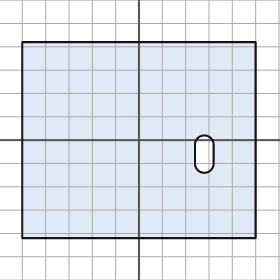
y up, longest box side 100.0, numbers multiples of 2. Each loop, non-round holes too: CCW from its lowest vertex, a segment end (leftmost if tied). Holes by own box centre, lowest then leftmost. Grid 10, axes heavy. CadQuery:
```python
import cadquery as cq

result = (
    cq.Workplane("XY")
    .moveTo(-50.0, -42.0)
    .lineTo(50.0, -42.0)
    .lineTo(50.0, 42.0)
    .lineTo(-50.0, 42.0)
    .close()
    .moveTo(24.0, -10.0)
    .threePointArc((28.0, -14.0), (32.0, -10.0))
    .lineTo(32.0, -2.0)
    .threePointArc((28.0, 2.0), (24.0, -2.0))
    .close()
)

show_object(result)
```